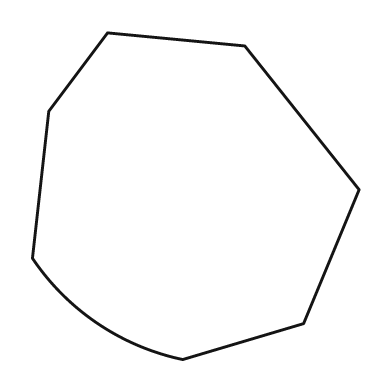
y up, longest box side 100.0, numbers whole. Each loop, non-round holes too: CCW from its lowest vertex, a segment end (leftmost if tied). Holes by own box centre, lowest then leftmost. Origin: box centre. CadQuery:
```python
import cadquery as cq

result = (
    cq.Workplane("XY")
    .moveTo(-4.0, -50.0)
    .lineTo(33.0, -39.0)
    .lineTo(50.0, 2.0)
    .lineTo(15.0, 46.0)
    .lineTo(-27.0, 50.0)
    .lineTo(-45.0, 26.0)
    .lineTo(-50.0, -19.0)
    .threePointArc((-30.0, -39.0), (-4.0, -50.0))
    .close()
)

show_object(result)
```